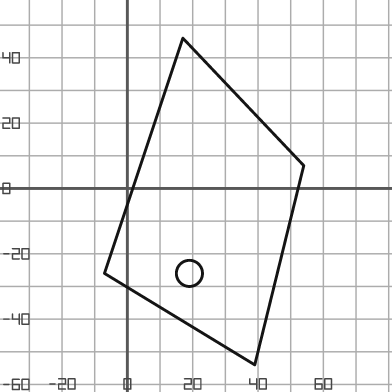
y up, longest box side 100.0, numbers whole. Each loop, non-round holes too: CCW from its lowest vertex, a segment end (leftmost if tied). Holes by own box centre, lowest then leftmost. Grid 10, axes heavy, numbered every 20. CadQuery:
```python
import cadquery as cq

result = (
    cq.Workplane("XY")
    .moveTo(39.0, -54.0)
    .lineTo(54.0, 7.0)
    .lineTo(17.0, 46.0)
    .lineTo(-7.0, -26.0)
    .close()
    .moveTo(19.0, -26.0)
    .circle(4.0)
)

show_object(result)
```